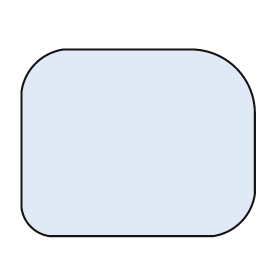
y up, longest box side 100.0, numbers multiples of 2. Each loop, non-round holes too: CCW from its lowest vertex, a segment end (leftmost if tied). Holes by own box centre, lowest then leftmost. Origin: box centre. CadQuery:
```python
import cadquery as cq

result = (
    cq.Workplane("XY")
    .moveTo(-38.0, -40.0)
    .lineTo(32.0, -40.0)
    .threePointArc((44.0, -34.0), (50.0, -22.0))
    .lineTo(50.0, 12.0)
    .threePointArc((42.0, 32.0), (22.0, 40.0))
    .lineTo(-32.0, 40.0)
    .threePointArc((-44.0, 34.0), (-50.0, 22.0))
    .lineTo(-50.0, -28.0)
    .threePointArc((-46.0, -36.0), (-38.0, -40.0))
    .close()
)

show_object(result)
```